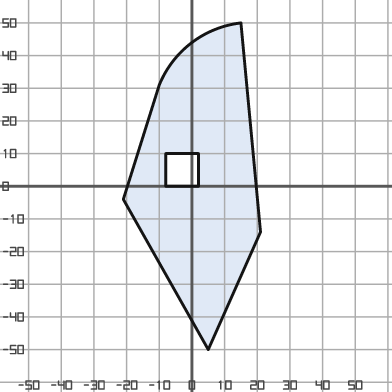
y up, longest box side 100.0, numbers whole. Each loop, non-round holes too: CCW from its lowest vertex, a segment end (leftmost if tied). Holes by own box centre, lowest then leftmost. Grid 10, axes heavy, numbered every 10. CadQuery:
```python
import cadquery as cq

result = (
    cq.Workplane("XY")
    .moveTo(5.0, -50.0)
    .lineTo(21.0, -14.0)
    .lineTo(15.0, 50.0)
    .threePointArc((0.0, 44.0), (-10.0, 31.0))
    .lineTo(-21.0, -4.0)
    .close()
    .moveTo(-8.0, 0.0)
    .lineTo(2.0, 0.0)
    .lineTo(2.0, 10.0)
    .lineTo(-8.0, 10.0)
    .close()
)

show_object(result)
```